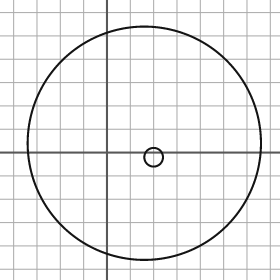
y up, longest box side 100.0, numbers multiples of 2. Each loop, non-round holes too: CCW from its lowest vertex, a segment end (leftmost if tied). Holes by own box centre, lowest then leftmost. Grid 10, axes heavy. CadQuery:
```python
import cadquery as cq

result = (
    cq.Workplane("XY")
    .moveTo(16.0, 4.0)
    .circle(50.0)
    .moveTo(20.0, -2.0)
    .circle(4.0)
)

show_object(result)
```